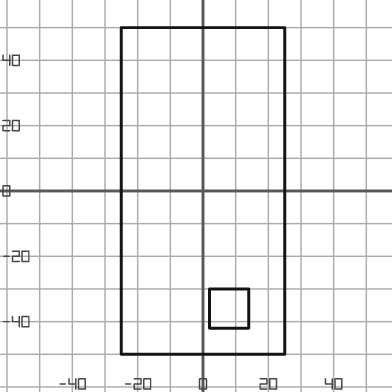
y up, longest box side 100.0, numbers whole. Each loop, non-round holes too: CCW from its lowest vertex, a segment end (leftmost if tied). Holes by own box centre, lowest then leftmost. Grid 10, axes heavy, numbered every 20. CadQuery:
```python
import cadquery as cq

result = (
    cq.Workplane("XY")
    .moveTo(-25.0, -50.0)
    .lineTo(25.0, -50.0)
    .lineTo(25.0, 50.0)
    .lineTo(-25.0, 50.0)
    .close()
    .moveTo(2.0, -42.0)
    .lineTo(14.0, -42.0)
    .lineTo(14.0, -30.0)
    .lineTo(2.0, -30.0)
    .close()
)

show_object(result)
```